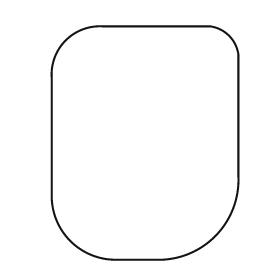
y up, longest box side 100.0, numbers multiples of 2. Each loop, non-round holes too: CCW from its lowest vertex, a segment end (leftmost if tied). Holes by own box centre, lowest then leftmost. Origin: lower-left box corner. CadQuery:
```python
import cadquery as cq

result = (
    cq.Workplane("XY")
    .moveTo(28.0, 0.0)
    .lineTo(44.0, 0.0)
    .threePointArc((70.0, 10.0), (80.0, 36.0))
    .lineTo(80.0, 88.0)
    .threePointArc((76.0, 96.0), (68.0, 100.0))
    .lineTo(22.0, 100.0)
    .threePointArc((6.0, 94.0), (0.0, 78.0))
    .lineTo(0.0, 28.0)
    .threePointArc((8.0, 8.0), (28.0, 0.0))
    .close()
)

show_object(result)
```